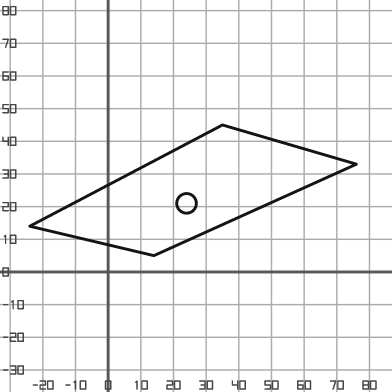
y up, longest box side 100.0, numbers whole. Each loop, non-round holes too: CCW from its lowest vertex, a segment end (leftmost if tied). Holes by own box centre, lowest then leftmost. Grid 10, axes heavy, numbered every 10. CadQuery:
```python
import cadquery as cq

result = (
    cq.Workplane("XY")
    .moveTo(14.0, 5.0)
    .lineTo(76.0, 33.0)
    .lineTo(35.0, 45.0)
    .lineTo(-24.0, 14.0)
    .close()
    .moveTo(24.0, 21.0)
    .circle(3.0)
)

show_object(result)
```